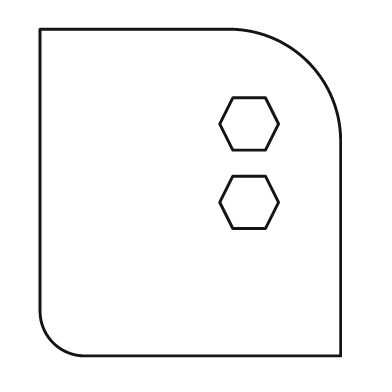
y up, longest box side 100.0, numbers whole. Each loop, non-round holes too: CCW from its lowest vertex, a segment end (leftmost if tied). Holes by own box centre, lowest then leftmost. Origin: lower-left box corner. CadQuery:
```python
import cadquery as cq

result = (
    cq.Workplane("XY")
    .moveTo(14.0, 0.0)
    .lineTo(92.0, 0.0)
    .lineTo(92.0, 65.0)
    .threePointArc((82.0, 90.0), (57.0, 100.0))
    .lineTo(0.0, 100.0)
    .lineTo(0.0, 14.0)
    .threePointArc((4.0, 4.0), (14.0, 0.0))
    .close()
    .moveTo(59.0, 39.0)
    .lineTo(69.0, 39.0)
    .lineTo(73.0, 47.0)
    .lineTo(69.0, 55.0)
    .lineTo(59.0, 55.0)
    .lineTo(55.0, 47.0)
    .close()
    .moveTo(59.0, 63.0)
    .lineTo(69.0, 63.0)
    .lineTo(73.0, 71.0)
    .lineTo(69.0, 79.0)
    .lineTo(59.0, 79.0)
    .lineTo(55.0, 71.0)
    .close()
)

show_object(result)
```